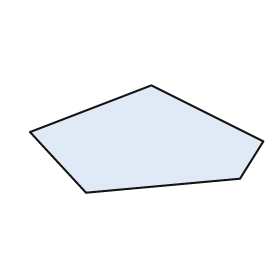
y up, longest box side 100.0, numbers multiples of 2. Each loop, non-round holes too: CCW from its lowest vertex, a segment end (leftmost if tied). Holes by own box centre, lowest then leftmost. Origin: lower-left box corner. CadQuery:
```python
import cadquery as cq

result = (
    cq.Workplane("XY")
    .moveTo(24.0, 0.0)
    .lineTo(90.0, 6.0)
    .lineTo(100.0, 22.0)
    .lineTo(52.0, 46.0)
    .lineTo(0.0, 26.0)
    .close()
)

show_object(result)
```